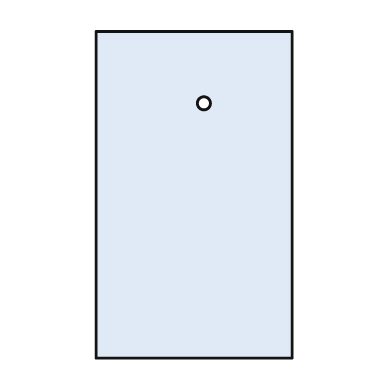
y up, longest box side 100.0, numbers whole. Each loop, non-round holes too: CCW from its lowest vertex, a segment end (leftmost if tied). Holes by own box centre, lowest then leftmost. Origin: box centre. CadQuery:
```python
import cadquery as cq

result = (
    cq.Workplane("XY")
    .moveTo(-30.0, -50.0)
    .lineTo(30.0, -50.0)
    .lineTo(30.0, 50.0)
    .lineTo(-30.0, 50.0)
    .close()
    .moveTo(3.0, 28.0)
    .circle(2.0)
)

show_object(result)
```